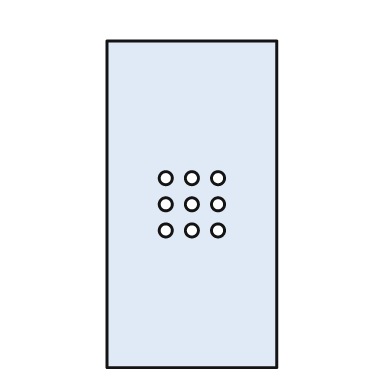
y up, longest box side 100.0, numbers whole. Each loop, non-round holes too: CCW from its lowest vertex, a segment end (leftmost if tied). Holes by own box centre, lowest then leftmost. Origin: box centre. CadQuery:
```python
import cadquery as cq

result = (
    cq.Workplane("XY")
    .moveTo(-26.0, -50.0)
    .lineTo(26.0, -50.0)
    .lineTo(26.0, 50.0)
    .lineTo(-26.0, 50.0)
    .close()
    .moveTo(-8.0, -8.0)
    .circle(2.0)
    .moveTo(0.0, -8.0)
    .circle(2.0)
    .moveTo(8.0, -8.0)
    .circle(2.0)
    .moveTo(-8.0, 0.0)
    .circle(2.0)
    .moveTo(0.0, 0.0)
    .circle(2.0)
    .moveTo(8.0, 0.0)
    .circle(2.0)
    .moveTo(-8.0, 8.0)
    .circle(2.0)
    .moveTo(0.0, 8.0)
    .circle(2.0)
    .moveTo(8.0, 8.0)
    .circle(2.0)
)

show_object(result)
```